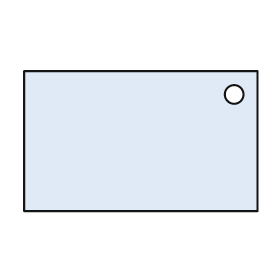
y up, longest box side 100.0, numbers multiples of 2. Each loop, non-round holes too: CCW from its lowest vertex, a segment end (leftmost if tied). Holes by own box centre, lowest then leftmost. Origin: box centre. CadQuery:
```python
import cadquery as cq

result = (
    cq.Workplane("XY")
    .moveTo(-50.0, -30.0)
    .lineTo(50.0, -30.0)
    .lineTo(50.0, 30.0)
    .lineTo(-50.0, 30.0)
    .close()
    .moveTo(40.0, 20.0)
    .circle(4.0)
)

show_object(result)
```